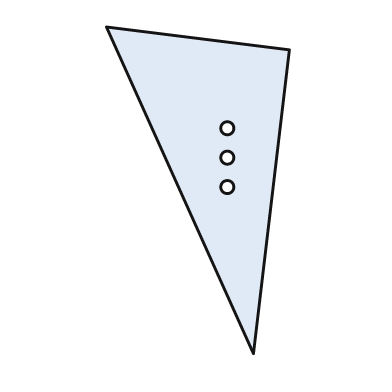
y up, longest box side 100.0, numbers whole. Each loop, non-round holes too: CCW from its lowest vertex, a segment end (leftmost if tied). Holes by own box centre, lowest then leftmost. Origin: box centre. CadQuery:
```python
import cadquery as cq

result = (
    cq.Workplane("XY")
    .moveTo(17.0, -50.0)
    .lineTo(28.0, 43.0)
    .lineTo(-28.0, 50.0)
    .close()
    .moveTo(9.0, 1.0)
    .circle(2.0)
    .moveTo(9.0, 10.0)
    .circle(2.0)
    .moveTo(9.0, 19.0)
    .circle(2.0)
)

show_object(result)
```